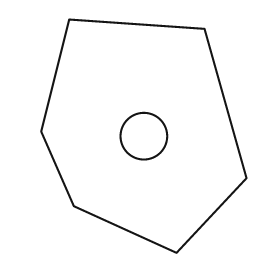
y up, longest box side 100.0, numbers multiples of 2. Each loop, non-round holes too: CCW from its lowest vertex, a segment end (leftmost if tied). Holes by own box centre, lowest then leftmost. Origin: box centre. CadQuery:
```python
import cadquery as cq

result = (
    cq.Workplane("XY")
    .moveTo(14.0, -50.0)
    .lineTo(44.0, -18.0)
    .lineTo(26.0, 46.0)
    .lineTo(-32.0, 50.0)
    .lineTo(-44.0, 2.0)
    .lineTo(-30.0, -30.0)
    .close()
    .moveTo(0.0, 0.0)
    .circle(10.0)
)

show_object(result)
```